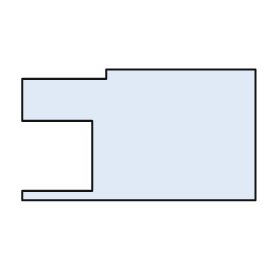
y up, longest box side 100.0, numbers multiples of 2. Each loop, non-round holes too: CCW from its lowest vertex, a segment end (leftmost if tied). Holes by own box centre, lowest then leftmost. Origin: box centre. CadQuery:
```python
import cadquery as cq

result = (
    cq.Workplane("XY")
    .moveTo(-50.0, -28.0)
    .lineTo(50.0, -28.0)
    .lineTo(50.0, 28.0)
    .lineTo(-14.0, 28.0)
    .lineTo(-14.0, 24.0)
    .lineTo(-50.0, 24.0)
    .lineTo(-50.0, 6.0)
    .lineTo(-20.0, 6.0)
    .lineTo(-20.0, -24.0)
    .lineTo(-50.0, -24.0)
    .close()
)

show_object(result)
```